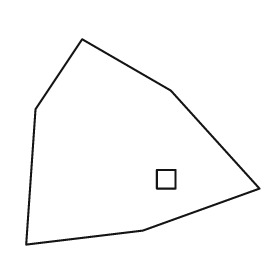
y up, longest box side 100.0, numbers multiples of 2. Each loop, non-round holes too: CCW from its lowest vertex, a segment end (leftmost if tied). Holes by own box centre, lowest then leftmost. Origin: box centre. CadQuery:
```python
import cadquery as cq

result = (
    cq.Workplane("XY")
    .moveTo(-50.0, -44.0)
    .lineTo(0.0, -38.0)
    .lineTo(50.0, -20.0)
    .lineTo(12.0, 22.0)
    .lineTo(-26.0, 44.0)
    .lineTo(-46.0, 14.0)
    .close()
    .moveTo(6.0, -20.0)
    .lineTo(14.0, -20.0)
    .lineTo(14.0, -12.0)
    .lineTo(6.0, -12.0)
    .close()
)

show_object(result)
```